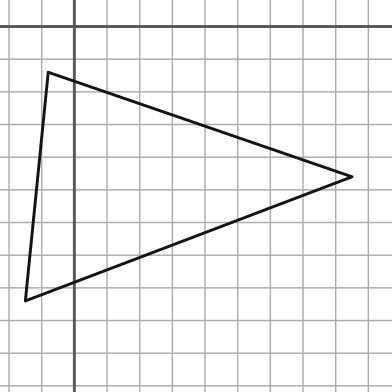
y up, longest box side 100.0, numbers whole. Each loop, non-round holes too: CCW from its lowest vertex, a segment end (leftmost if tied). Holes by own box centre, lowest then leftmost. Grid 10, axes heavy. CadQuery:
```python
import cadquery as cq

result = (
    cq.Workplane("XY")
    .moveTo(-15.0, -84.0)
    .lineTo(85.0, -46.0)
    .lineTo(-8.0, -14.0)
    .close()
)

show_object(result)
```